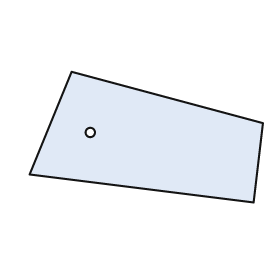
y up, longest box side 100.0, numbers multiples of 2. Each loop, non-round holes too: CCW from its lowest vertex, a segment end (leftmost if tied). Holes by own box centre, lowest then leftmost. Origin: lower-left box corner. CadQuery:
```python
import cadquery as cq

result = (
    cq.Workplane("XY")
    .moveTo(96.0, 0.0)
    .lineTo(100.0, 34.0)
    .lineTo(18.0, 56.0)
    .lineTo(0.0, 12.0)
    .close()
    .moveTo(26.0, 30.0)
    .circle(2.0)
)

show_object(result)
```